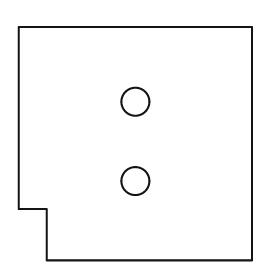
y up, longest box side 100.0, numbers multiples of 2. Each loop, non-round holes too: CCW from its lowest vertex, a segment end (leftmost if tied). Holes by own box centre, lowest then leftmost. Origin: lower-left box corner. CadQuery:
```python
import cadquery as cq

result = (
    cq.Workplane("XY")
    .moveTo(12.0, 0.0)
    .lineTo(100.0, 0.0)
    .lineTo(100.0, 100.0)
    .lineTo(0.0, 100.0)
    .lineTo(0.0, 22.0)
    .lineTo(12.0, 22.0)
    .close()
    .moveTo(50.0, 34.0)
    .circle(6.0)
    .moveTo(50.0, 68.0)
    .circle(6.0)
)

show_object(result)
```